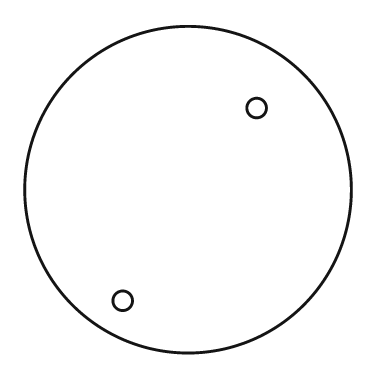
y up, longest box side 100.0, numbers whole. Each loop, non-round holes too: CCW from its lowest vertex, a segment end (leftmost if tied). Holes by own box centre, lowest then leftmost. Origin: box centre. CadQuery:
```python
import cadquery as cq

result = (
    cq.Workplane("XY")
    .moveTo(0.0, 0.0)
    .circle(50.0)
    .moveTo(-20.0, -34.0)
    .circle(3.0)
    .moveTo(21.0, 25.0)
    .circle(3.0)
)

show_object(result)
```